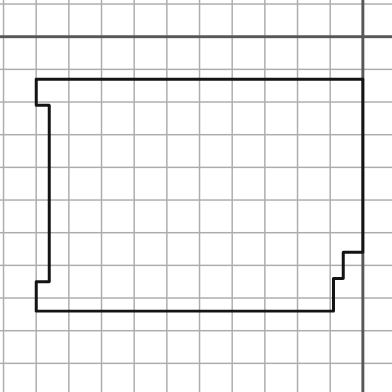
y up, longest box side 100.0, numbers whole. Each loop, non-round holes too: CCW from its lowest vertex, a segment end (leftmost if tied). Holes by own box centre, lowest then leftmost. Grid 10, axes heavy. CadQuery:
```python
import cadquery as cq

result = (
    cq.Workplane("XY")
    .moveTo(-100.0, -84.0)
    .lineTo(-9.0, -84.0)
    .lineTo(-9.0, -74.0)
    .lineTo(-6.0, -74.0)
    .lineTo(-6.0, -66.0)
    .lineTo(0.0, -66.0)
    .lineTo(0.0, -13.0)
    .lineTo(-100.0, -13.0)
    .lineTo(-100.0, -21.0)
    .lineTo(-96.0, -21.0)
    .lineTo(-96.0, -75.0)
    .lineTo(-100.0, -75.0)
    .close()
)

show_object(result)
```